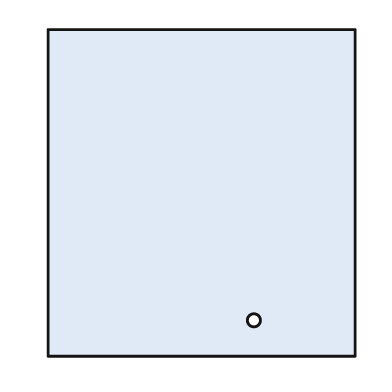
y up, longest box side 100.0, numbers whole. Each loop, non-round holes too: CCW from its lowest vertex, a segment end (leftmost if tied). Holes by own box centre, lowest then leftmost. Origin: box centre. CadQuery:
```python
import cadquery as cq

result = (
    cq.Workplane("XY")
    .moveTo(-47.0, -50.0)
    .lineTo(47.0, -50.0)
    .lineTo(47.0, 50.0)
    .lineTo(-47.0, 50.0)
    .close()
    .moveTo(16.0, -39.0)
    .circle(2.0)
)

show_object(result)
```